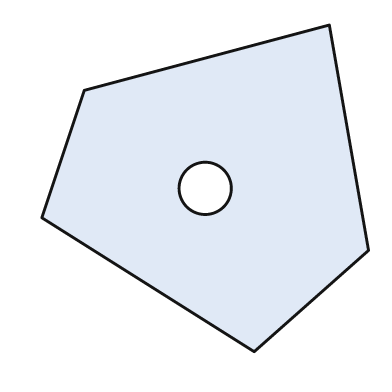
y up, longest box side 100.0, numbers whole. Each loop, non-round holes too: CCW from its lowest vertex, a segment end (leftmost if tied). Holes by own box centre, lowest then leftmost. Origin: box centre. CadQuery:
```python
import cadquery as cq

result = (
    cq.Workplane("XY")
    .moveTo(15.0, -50.0)
    .lineTo(50.0, -19.0)
    .lineTo(38.0, 50.0)
    .lineTo(-37.0, 30.0)
    .lineTo(-50.0, -9.0)
    .close()
    .moveTo(0.0, 0.0)
    .circle(8.0)
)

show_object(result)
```